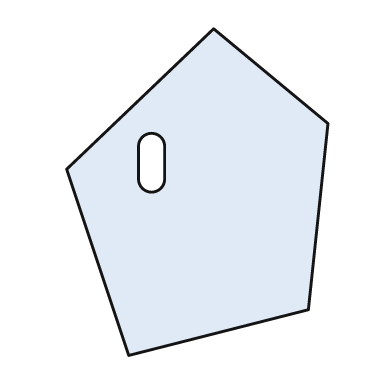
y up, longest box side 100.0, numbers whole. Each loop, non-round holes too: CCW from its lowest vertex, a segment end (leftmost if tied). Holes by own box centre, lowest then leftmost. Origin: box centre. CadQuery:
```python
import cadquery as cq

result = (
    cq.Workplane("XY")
    .moveTo(-21.0, -50.0)
    .lineTo(34.0, -36.0)
    .lineTo(40.0, 21.0)
    .lineTo(5.0, 50.0)
    .lineTo(-40.0, 7.0)
    .close()
    .moveTo(-18.0, 4.0)
    .threePointArc((-14.0, 0.0), (-10.0, 4.0))
    .lineTo(-10.0, 14.0)
    .threePointArc((-14.0, 18.0), (-18.0, 14.0))
    .close()
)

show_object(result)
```